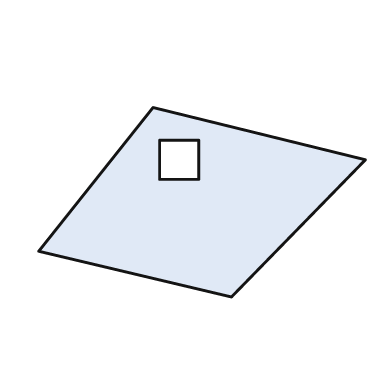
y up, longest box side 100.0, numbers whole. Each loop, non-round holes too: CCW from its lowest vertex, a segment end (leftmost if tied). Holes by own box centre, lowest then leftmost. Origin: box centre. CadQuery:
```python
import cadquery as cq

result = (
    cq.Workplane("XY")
    .moveTo(9.0, -29.0)
    .lineTo(50.0, 13.0)
    .lineTo(-15.0, 29.0)
    .lineTo(-50.0, -15.0)
    .close()
    .moveTo(-13.0, 7.0)
    .lineTo(-1.0, 7.0)
    .lineTo(-1.0, 19.0)
    .lineTo(-13.0, 19.0)
    .close()
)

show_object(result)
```